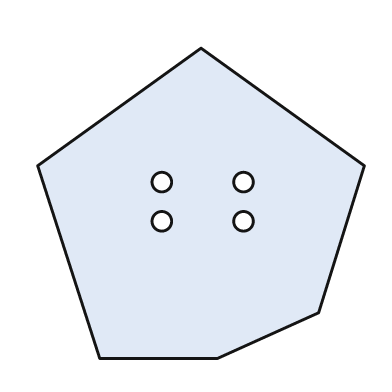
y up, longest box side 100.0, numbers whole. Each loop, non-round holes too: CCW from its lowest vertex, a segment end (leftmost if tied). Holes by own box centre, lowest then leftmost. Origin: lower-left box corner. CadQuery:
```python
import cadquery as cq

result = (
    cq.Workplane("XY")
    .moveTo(19.0, 0.0)
    .lineTo(55.0, 0.0)
    .lineTo(86.0, 14.0)
    .lineTo(100.0, 59.0)
    .lineTo(50.0, 95.0)
    .lineTo(0.0, 59.0)
    .close()
    .moveTo(38.0, 42.0)
    .circle(3.0)
    .moveTo(63.0, 42.0)
    .circle(3.0)
    .moveTo(38.0, 54.0)
    .circle(3.0)
    .moveTo(63.0, 54.0)
    .circle(3.0)
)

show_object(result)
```